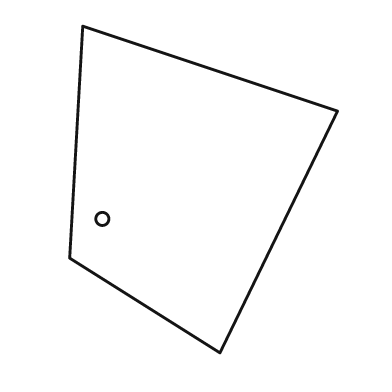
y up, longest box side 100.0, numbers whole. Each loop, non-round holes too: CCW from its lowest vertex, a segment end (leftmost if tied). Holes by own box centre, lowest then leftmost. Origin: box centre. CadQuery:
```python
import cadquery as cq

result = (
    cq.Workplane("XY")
    .moveTo(5.0, -50.0)
    .lineTo(41.0, 24.0)
    .lineTo(-37.0, 50.0)
    .lineTo(-41.0, -21.0)
    .close()
    .moveTo(-31.0, -9.0)
    .circle(2.0)
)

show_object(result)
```